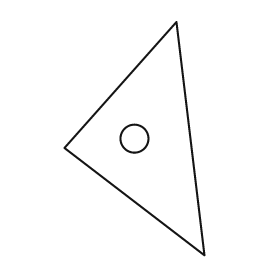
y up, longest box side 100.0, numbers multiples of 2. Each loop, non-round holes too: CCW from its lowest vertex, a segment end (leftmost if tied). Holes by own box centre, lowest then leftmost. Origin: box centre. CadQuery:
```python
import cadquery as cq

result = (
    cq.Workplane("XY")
    .moveTo(30.0, -50.0)
    .lineTo(18.0, 50.0)
    .lineTo(-30.0, -4.0)
    .close()
    .moveTo(0.0, 0.0)
    .circle(6.0)
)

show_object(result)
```